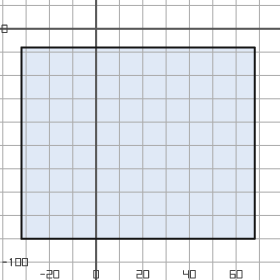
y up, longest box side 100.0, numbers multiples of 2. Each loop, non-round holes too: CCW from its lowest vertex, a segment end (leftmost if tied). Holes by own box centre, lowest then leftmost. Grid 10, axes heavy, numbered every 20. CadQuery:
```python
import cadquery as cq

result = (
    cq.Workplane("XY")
    .moveTo(-32.0, -90.0)
    .lineTo(68.0, -90.0)
    .lineTo(68.0, -8.0)
    .lineTo(-32.0, -8.0)
    .close()
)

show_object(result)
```